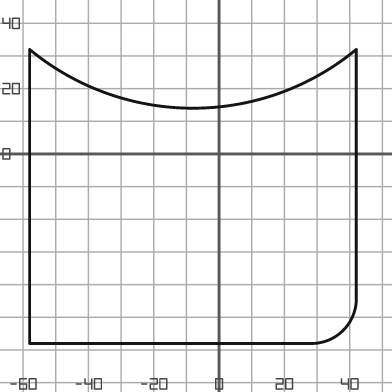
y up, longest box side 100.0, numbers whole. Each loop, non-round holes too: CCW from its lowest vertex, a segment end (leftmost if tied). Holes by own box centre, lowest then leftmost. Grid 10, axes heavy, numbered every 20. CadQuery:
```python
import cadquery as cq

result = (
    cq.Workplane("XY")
    .moveTo(-58.0, -58.0)
    .lineTo(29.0, -58.0)
    .threePointArc((38.0, -54.0), (42.0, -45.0))
    .lineTo(42.0, 32.0)
    .threePointArc((-8.0, 14.0), (-58.0, 32.0))
    .close()
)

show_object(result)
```